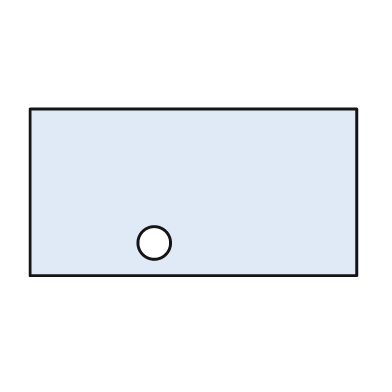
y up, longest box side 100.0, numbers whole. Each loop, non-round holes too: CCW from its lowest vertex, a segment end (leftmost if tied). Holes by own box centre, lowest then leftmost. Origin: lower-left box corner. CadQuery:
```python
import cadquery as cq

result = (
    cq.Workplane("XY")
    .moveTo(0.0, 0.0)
    .lineTo(100.0, 0.0)
    .lineTo(100.0, 51.0)
    .lineTo(0.0, 51.0)
    .close()
    .moveTo(38.0, 10.0)
    .circle(5.0)
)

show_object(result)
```